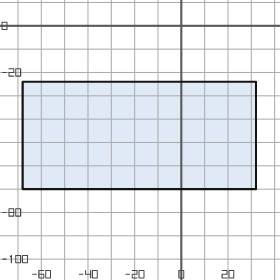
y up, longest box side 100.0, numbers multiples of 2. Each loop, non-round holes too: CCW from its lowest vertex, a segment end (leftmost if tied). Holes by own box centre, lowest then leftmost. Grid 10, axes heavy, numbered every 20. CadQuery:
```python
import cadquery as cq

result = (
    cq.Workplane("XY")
    .moveTo(-68.0, -70.0)
    .lineTo(32.0, -70.0)
    .lineTo(32.0, -24.0)
    .lineTo(-68.0, -24.0)
    .close()
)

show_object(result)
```